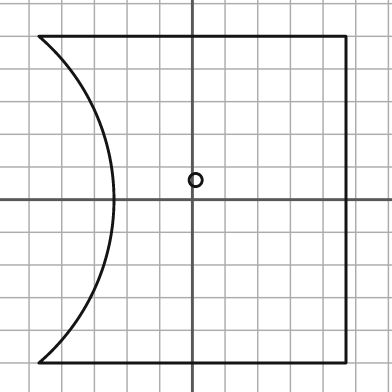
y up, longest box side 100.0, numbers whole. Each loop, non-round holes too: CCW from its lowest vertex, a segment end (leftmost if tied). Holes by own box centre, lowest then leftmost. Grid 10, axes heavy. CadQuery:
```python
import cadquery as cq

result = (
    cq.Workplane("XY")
    .moveTo(-47.0, -50.0)
    .lineTo(47.0, -50.0)
    .lineTo(47.0, 50.0)
    .lineTo(-47.0, 50.0)
    .threePointArc((-24.0, 0.0), (-47.0, -50.0))
    .close()
    .moveTo(1.0, 6.0)
    .circle(2.0)
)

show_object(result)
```